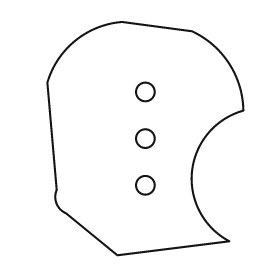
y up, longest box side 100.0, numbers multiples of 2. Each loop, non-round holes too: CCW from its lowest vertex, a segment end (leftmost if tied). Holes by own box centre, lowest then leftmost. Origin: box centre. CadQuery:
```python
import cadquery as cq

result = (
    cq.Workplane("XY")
    .moveTo(-12.0, -50.0)
    .lineTo(36.0, -44.0)
    .threePointArc((20.0, -14.0), (42.0, 12.0))
    .threePointArc((36.0, 32.0), (20.0, 46.0))
    .lineTo(-10.0, 50.0)
    .threePointArc((-30.0, 42.0), (-42.0, 24.0))
    .lineTo(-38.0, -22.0)
    .threePointArc((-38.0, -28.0), (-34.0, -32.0))
    .close()
    .moveTo(0.0, -20.0)
    .circle(4.0)
    .moveTo(0.0, 0.0)
    .circle(4.0)
    .moveTo(0.0, 20.0)
    .circle(4.0)
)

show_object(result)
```